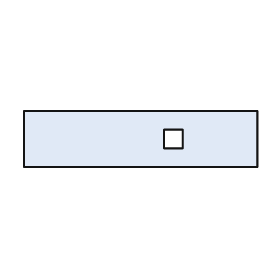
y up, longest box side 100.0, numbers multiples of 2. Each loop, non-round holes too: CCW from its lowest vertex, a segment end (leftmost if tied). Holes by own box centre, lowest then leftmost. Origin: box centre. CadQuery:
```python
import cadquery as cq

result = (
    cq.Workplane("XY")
    .moveTo(-50.0, -12.0)
    .lineTo(50.0, -12.0)
    .lineTo(50.0, 12.0)
    .lineTo(-50.0, 12.0)
    .close()
    .moveTo(10.0, -4.0)
    .lineTo(18.0, -4.0)
    .lineTo(18.0, 4.0)
    .lineTo(10.0, 4.0)
    .close()
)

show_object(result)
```